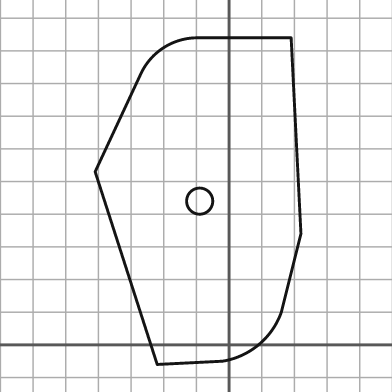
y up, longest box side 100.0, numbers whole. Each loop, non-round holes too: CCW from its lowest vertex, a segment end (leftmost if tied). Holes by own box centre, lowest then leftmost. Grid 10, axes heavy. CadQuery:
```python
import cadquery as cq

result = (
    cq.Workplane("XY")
    .moveTo(-22.0, -6.0)
    .lineTo(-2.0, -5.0)
    .threePointArc((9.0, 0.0), (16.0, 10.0))
    .lineTo(22.0, 34.0)
    .lineTo(19.0, 94.0)
    .lineTo(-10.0, 94.0)
    .threePointArc((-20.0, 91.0), (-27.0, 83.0))
    .lineTo(-41.0, 53.0)
    .close()
    .moveTo(-9.0, 44.0)
    .circle(4.0)
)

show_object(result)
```